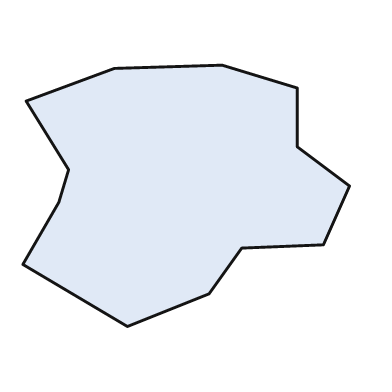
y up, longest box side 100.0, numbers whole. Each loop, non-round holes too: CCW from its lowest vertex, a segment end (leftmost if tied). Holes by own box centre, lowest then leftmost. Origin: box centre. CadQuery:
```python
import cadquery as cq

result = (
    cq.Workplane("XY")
    .moveTo(-18.0, -40.0)
    .lineTo(7.0, -30.0)
    .lineTo(17.0, -16.0)
    .lineTo(42.0, -15.0)
    .lineTo(50.0, 3.0)
    .lineTo(34.0, 15.0)
    .lineTo(34.0, 33.0)
    .lineTo(11.0, 40.0)
    .lineTo(-22.0, 39.0)
    .lineTo(-49.0, 29.0)
    .lineTo(-36.0, 8.0)
    .lineTo(-39.0, -2.0)
    .lineTo(-50.0, -21.0)
    .close()
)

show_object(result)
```